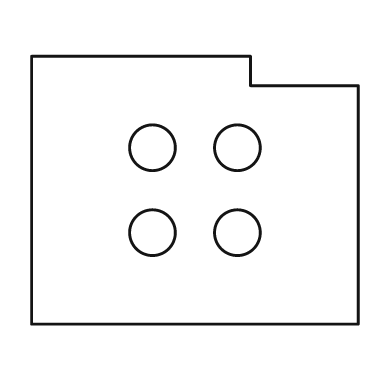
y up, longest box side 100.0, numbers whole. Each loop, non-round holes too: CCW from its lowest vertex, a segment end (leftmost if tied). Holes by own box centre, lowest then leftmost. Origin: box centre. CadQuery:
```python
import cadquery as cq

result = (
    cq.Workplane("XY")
    .moveTo(-50.0, -41.0)
    .lineTo(50.0, -41.0)
    .lineTo(50.0, 32.0)
    .lineTo(17.0, 32.0)
    .lineTo(17.0, 41.0)
    .lineTo(-50.0, 41.0)
    .close()
    .moveTo(-13.0, -13.0)
    .circle(7.0)
    .moveTo(13.0, -13.0)
    .circle(7.0)
    .moveTo(-13.0, 13.0)
    .circle(7.0)
    .moveTo(13.0, 13.0)
    .circle(7.0)
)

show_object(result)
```